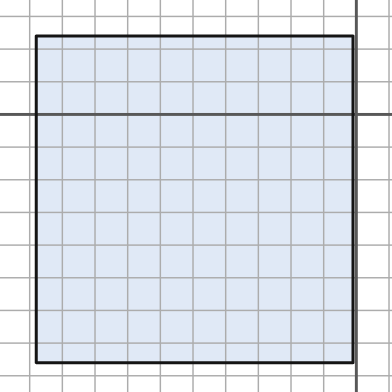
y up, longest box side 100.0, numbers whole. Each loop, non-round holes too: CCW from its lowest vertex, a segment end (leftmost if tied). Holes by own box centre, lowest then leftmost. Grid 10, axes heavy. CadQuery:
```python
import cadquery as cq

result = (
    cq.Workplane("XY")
    .moveTo(-98.0, -76.0)
    .lineTo(-1.0, -76.0)
    .lineTo(-1.0, 24.0)
    .lineTo(-98.0, 24.0)
    .close()
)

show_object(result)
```